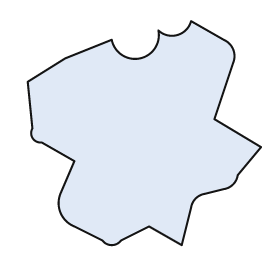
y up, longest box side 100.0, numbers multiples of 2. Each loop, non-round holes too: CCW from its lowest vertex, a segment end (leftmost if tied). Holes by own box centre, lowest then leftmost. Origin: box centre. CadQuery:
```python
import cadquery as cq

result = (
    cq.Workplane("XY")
    .moveTo(16.0, -48.0)
    .lineTo(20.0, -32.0)
    .threePointArc((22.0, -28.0), (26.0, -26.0))
    .lineTo(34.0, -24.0)
    .threePointArc((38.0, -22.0), (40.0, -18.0))
    .lineTo(50.0, -6.0)
    .lineTo(30.0, 6.0)
    .lineTo(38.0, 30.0)
    .threePointArc((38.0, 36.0), (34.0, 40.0))
    .lineTo(20.0, 48.0)
    .threePointArc((14.0, 42.0), (6.0, 44.0))
    .threePointArc((-2.0, 32.0), (-14.0, 40.0))
    .lineTo(-34.0, 32.0)
    .lineTo(-50.0, 22.0)
    .lineTo(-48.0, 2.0)
    .threePointArc((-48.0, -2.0), (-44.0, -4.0))
    .lineTo(-30.0, -12.0)
    .lineTo(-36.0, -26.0)
    .threePointArc((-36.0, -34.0), (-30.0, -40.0))
    .lineTo(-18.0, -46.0)
    .threePointArc((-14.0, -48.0), (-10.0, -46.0))
    .lineTo(2.0, -40.0)
    .close()
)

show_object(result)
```